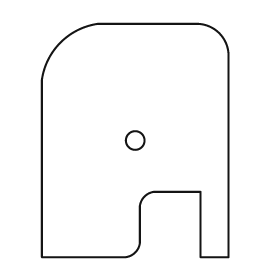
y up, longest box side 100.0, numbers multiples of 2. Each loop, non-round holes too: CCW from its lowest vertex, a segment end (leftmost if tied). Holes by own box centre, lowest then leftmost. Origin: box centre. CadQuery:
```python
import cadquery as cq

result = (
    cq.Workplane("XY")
    .moveTo(-40.0, -50.0)
    .lineTo(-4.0, -50.0)
    .threePointArc((0.0, -48.0), (2.0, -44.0))
    .lineTo(2.0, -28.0)
    .threePointArc((4.0, -24.0), (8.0, -22.0))
    .lineTo(28.0, -22.0)
    .lineTo(28.0, -50.0)
    .lineTo(40.0, -50.0)
    .lineTo(40.0, 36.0)
    .threePointArc((36.0, 46.0), (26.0, 50.0))
    .lineTo(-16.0, 50.0)
    .threePointArc((-32.0, 42.0), (-40.0, 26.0))
    .close()
    .moveTo(0.0, 0.0)
    .circle(4.0)
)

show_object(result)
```